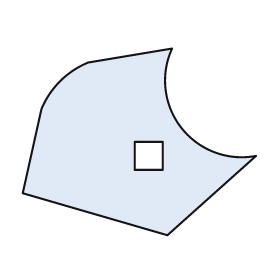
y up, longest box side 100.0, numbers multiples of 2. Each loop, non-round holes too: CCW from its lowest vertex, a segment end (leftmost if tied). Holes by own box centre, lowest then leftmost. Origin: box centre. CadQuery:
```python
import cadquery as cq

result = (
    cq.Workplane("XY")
    .moveTo(12.0, -40.0)
    .lineTo(50.0, -6.0)
    .threePointArc((18.0, 6.0), (14.0, 40.0))
    .lineTo(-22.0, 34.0)
    .threePointArc((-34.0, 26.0), (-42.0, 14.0))
    .lineTo(-50.0, -22.0)
    .close()
    .moveTo(-2.0, -12.0)
    .lineTo(10.0, -12.0)
    .lineTo(10.0, 0.0)
    .lineTo(-2.0, 0.0)
    .close()
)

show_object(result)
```